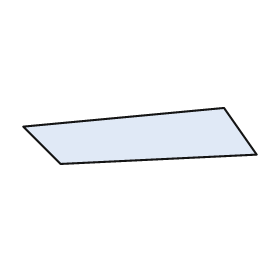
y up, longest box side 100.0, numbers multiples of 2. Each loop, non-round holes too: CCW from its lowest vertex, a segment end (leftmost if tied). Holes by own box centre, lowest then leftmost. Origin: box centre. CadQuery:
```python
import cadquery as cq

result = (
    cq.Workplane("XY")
    .moveTo(-34.0, -12.0)
    .lineTo(50.0, -8.0)
    .lineTo(36.0, 12.0)
    .lineTo(-50.0, 4.0)
    .close()
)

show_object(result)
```